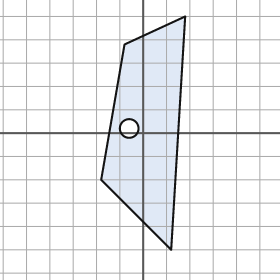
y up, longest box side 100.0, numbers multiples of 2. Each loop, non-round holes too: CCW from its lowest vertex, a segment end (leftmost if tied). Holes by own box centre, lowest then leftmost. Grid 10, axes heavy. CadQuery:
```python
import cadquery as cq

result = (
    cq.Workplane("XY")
    .moveTo(12.0, -50.0)
    .lineTo(18.0, 50.0)
    .lineTo(-8.0, 38.0)
    .lineTo(-18.0, -20.0)
    .close()
    .moveTo(-6.0, 2.0)
    .circle(4.0)
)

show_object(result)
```